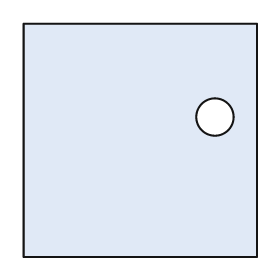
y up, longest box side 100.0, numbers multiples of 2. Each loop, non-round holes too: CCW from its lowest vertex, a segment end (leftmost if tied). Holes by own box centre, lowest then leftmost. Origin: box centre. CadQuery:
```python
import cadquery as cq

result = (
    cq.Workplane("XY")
    .moveTo(-50.0, -50.0)
    .lineTo(50.0, -50.0)
    .lineTo(50.0, 50.0)
    .lineTo(-50.0, 50.0)
    .close()
    .moveTo(32.0, 10.0)
    .circle(8.0)
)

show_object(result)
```